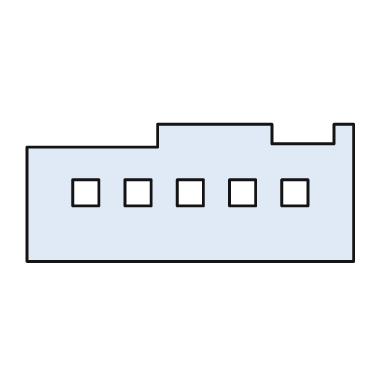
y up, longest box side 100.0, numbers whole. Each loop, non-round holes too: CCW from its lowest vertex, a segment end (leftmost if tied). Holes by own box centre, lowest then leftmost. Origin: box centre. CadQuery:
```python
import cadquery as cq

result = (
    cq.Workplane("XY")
    .moveTo(-50.0, -21.0)
    .lineTo(50.0, -21.0)
    .lineTo(50.0, 21.0)
    .lineTo(44.0, 21.0)
    .lineTo(44.0, 15.0)
    .lineTo(25.0, 15.0)
    .lineTo(25.0, 21.0)
    .lineTo(-10.0, 21.0)
    .lineTo(-10.0, 14.0)
    .lineTo(-50.0, 14.0)
    .close()
    .moveTo(-36.0, -4.0)
    .lineTo(-28.0, -4.0)
    .lineTo(-28.0, 4.0)
    .lineTo(-36.0, 4.0)
    .close()
    .moveTo(-20.0, -4.0)
    .lineTo(-12.0, -4.0)
    .lineTo(-12.0, 4.0)
    .lineTo(-20.0, 4.0)
    .close()
    .moveTo(-4.0, -4.0)
    .lineTo(4.0, -4.0)
    .lineTo(4.0, 4.0)
    .lineTo(-4.0, 4.0)
    .close()
    .moveTo(12.0, -4.0)
    .lineTo(20.0, -4.0)
    .lineTo(20.0, 4.0)
    .lineTo(12.0, 4.0)
    .close()
    .moveTo(28.0, -4.0)
    .lineTo(36.0, -4.0)
    .lineTo(36.0, 4.0)
    .lineTo(28.0, 4.0)
    .close()
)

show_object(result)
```